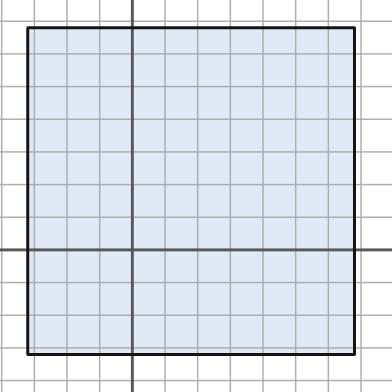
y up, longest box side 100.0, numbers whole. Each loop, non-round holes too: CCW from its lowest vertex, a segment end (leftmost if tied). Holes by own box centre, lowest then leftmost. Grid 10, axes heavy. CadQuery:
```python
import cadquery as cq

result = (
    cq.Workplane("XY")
    .moveTo(-32.0, -32.0)
    .lineTo(68.0, -32.0)
    .lineTo(68.0, 68.0)
    .lineTo(-32.0, 68.0)
    .close()
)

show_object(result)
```